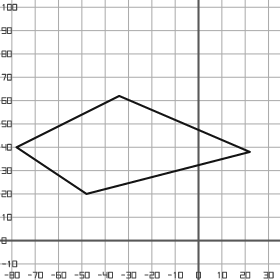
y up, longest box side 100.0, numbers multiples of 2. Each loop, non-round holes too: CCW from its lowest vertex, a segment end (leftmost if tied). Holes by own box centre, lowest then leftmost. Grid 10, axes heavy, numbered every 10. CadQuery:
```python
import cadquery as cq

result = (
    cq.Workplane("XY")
    .moveTo(-48.0, 20.0)
    .lineTo(22.0, 38.0)
    .lineTo(-34.0, 62.0)
    .lineTo(-78.0, 40.0)
    .close()
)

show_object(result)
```